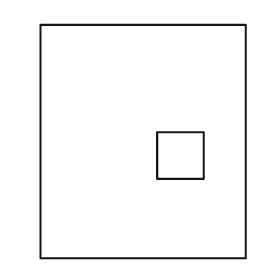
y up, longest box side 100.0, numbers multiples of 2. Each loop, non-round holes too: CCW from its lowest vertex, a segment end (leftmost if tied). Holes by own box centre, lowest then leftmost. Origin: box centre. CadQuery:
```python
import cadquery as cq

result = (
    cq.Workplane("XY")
    .moveTo(-44.0, -50.0)
    .lineTo(44.0, -50.0)
    .lineTo(44.0, 50.0)
    .lineTo(-44.0, 50.0)
    .close()
    .moveTo(6.0, -16.0)
    .lineTo(26.0, -16.0)
    .lineTo(26.0, 4.0)
    .lineTo(6.0, 4.0)
    .close()
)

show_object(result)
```